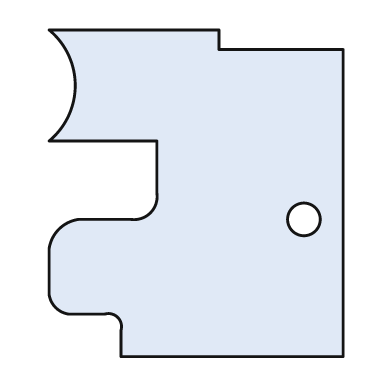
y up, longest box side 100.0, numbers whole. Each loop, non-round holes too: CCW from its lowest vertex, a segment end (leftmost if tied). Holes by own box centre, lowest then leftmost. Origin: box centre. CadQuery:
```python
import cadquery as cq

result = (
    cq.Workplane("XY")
    .moveTo(-23.0, -50.0)
    .lineTo(45.0, -50.0)
    .lineTo(45.0, 44.0)
    .lineTo(7.0, 44.0)
    .lineTo(7.0, 50.0)
    .lineTo(-45.0, 50.0)
    .threePointArc((-37.0, 33.0), (-45.0, 16.0))
    .lineTo(-12.0, 16.0)
    .lineTo(-12.0, 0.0)
    .threePointArc((-14.0, -6.0), (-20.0, -8.0))
    .lineTo(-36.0, -8.0)
    .threePointArc((-42.0, -11.0), (-45.0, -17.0))
    .lineTo(-45.0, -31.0)
    .threePointArc((-43.0, -35.0), (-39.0, -37.0))
    .lineTo(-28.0, -37.0)
    .threePointArc((-24.0, -38.0), (-23.0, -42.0))
    .close()
    .moveTo(33.0, -8.0)
    .circle(5.0)
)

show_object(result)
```